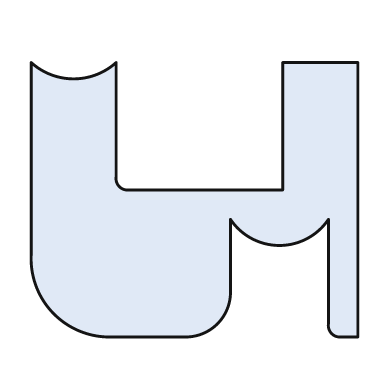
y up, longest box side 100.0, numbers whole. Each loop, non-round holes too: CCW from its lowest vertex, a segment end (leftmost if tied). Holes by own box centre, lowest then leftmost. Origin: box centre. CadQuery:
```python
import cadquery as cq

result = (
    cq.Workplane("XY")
    .moveTo(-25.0, -42.0)
    .lineTo(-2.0, -42.0)
    .threePointArc((7.0, -38.0), (11.0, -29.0))
    .lineTo(11.0, -6.0)
    .threePointArc((26.0, -14.0), (41.0, -6.0))
    .lineTo(41.0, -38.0)
    .threePointArc((42.0, -41.0), (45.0, -42.0))
    .lineTo(50.0, -42.0)
    .lineTo(50.0, 42.0)
    .lineTo(27.0, 42.0)
    .lineTo(27.0, 3.0)
    .lineTo(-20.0, 3.0)
    .threePointArc((-23.0, 4.0), (-24.0, 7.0))
    .lineTo(-24.0, 42.0)
    .threePointArc((-37.0, 37.0), (-50.0, 42.0))
    .lineTo(-50.0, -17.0)
    .threePointArc((-43.0, -35.0), (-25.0, -42.0))
    .close()
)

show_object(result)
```